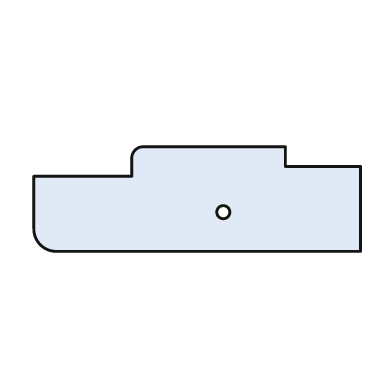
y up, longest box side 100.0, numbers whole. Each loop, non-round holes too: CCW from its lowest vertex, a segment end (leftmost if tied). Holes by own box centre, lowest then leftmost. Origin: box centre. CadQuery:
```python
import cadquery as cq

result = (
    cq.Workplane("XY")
    .moveTo(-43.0, -16.0)
    .lineTo(50.0, -16.0)
    .lineTo(50.0, 10.0)
    .lineTo(27.0, 10.0)
    .lineTo(27.0, 16.0)
    .lineTo(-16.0, 16.0)
    .threePointArc((-19.0, 15.0), (-20.0, 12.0))
    .lineTo(-20.0, 7.0)
    .lineTo(-50.0, 7.0)
    .lineTo(-50.0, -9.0)
    .threePointArc((-48.0, -14.0), (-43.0, -16.0))
    .close()
    .moveTo(8.0, -4.0)
    .circle(2.0)
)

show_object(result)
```